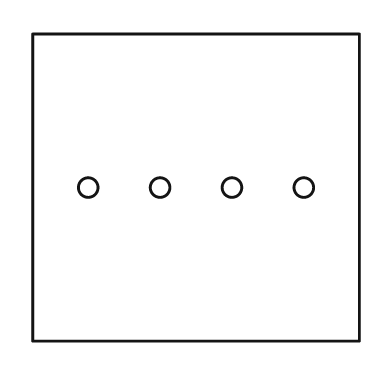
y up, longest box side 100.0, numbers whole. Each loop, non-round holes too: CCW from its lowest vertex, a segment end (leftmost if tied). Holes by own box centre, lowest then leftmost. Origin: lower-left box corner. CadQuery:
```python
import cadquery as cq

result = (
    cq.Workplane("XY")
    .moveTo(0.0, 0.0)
    .lineTo(100.0, 0.0)
    .lineTo(100.0, 94.0)
    .lineTo(0.0, 94.0)
    .close()
    .moveTo(17.0, 47.0)
    .circle(3.0)
    .moveTo(39.0, 47.0)
    .circle(3.0)
    .moveTo(61.0, 47.0)
    .circle(3.0)
    .moveTo(83.0, 47.0)
    .circle(3.0)
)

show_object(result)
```